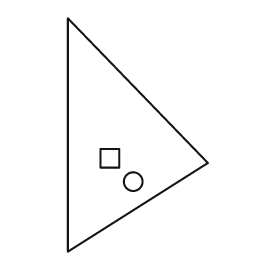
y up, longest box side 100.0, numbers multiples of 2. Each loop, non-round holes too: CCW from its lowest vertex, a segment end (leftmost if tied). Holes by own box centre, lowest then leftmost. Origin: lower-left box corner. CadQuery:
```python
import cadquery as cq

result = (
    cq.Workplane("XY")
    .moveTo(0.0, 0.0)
    .lineTo(60.0, 38.0)
    .lineTo(0.0, 100.0)
    .close()
    .moveTo(28.0, 30.0)
    .circle(4.0)
    .moveTo(14.0, 36.0)
    .lineTo(22.0, 36.0)
    .lineTo(22.0, 44.0)
    .lineTo(14.0, 44.0)
    .close()
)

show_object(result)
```